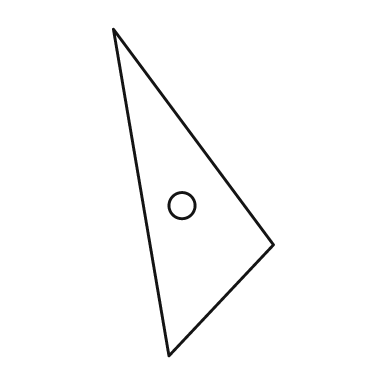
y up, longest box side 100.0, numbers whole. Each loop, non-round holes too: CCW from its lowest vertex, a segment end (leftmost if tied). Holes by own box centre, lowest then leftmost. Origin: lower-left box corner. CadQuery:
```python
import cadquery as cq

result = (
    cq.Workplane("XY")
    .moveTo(17.0, 0.0)
    .lineTo(49.0, 34.0)
    .lineTo(0.0, 100.0)
    .close()
    .moveTo(21.0, 46.0)
    .circle(4.0)
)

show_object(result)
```